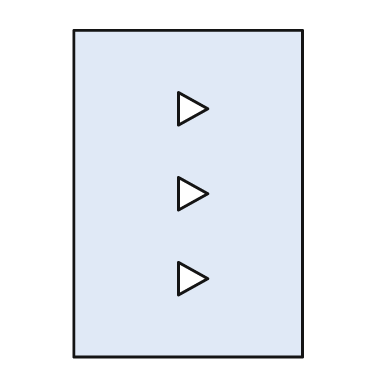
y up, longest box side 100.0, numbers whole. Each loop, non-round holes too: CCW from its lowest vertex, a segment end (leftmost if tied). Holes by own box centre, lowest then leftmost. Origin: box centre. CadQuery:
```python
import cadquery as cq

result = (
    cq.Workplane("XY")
    .moveTo(-35.0, -50.0)
    .lineTo(35.0, -50.0)
    .lineTo(35.0, 50.0)
    .lineTo(-35.0, 50.0)
    .close()
    .moveTo(-3.0, -31.0)
    .lineTo(6.0, -26.0)
    .lineTo(-3.0, -21.0)
    .close()
    .moveTo(-3.0, -5.0)
    .lineTo(6.0, 0.0)
    .lineTo(-3.0, 5.0)
    .close()
    .moveTo(-3.0, 21.0)
    .lineTo(6.0, 26.0)
    .lineTo(-3.0, 31.0)
    .close()
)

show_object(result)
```